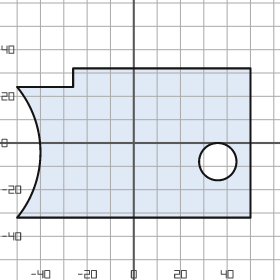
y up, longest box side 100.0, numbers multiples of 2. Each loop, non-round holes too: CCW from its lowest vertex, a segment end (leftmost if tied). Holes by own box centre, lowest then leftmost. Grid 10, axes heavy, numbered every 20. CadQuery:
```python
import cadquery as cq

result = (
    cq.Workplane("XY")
    .moveTo(-50.0, -32.0)
    .lineTo(50.0, -32.0)
    .lineTo(50.0, 32.0)
    .lineTo(-26.0, 32.0)
    .lineTo(-26.0, 24.0)
    .lineTo(-50.0, 24.0)
    .threePointArc((-40.0, -4.0), (-50.0, -32.0))
    .close()
    .moveTo(36.0, -8.0)
    .circle(8.0)
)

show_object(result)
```